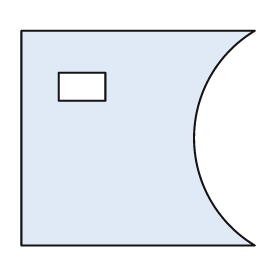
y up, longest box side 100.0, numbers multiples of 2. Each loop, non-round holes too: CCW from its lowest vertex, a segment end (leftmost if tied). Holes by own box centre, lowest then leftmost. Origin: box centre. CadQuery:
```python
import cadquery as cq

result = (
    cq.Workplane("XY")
    .moveTo(-50.0, -46.0)
    .lineTo(50.0, -46.0)
    .threePointArc((24.0, 0.0), (50.0, 46.0))
    .lineTo(-50.0, 46.0)
    .close()
    .moveTo(-34.0, 16.0)
    .lineTo(-14.0, 16.0)
    .lineTo(-14.0, 28.0)
    .lineTo(-34.0, 28.0)
    .close()
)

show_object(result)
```